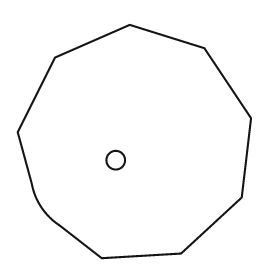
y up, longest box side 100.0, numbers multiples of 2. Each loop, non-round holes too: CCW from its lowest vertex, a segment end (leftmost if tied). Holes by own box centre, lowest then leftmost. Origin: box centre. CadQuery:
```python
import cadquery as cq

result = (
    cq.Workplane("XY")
    .moveTo(-14.0, -50.0)
    .lineTo(20.0, -48.0)
    .lineTo(46.0, -24.0)
    .lineTo(50.0, 10.0)
    .lineTo(30.0, 40.0)
    .lineTo(-2.0, 50.0)
    .lineTo(-34.0, 36.0)
    .lineTo(-50.0, 4.0)
    .lineTo(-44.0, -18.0)
    .threePointArc((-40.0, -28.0), (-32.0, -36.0))
    .close()
    .moveTo(-8.0, -8.0)
    .circle(4.0)
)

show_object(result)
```